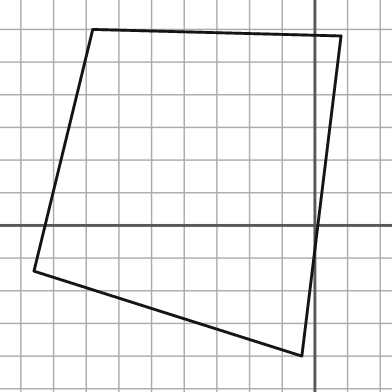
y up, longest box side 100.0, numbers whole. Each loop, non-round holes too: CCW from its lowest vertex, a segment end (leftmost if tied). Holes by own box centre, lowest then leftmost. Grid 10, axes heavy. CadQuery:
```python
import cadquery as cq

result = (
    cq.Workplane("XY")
    .moveTo(-4.0, -40.0)
    .lineTo(8.0, 58.0)
    .lineTo(-68.0, 60.0)
    .lineTo(-86.0, -14.0)
    .close()
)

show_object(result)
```